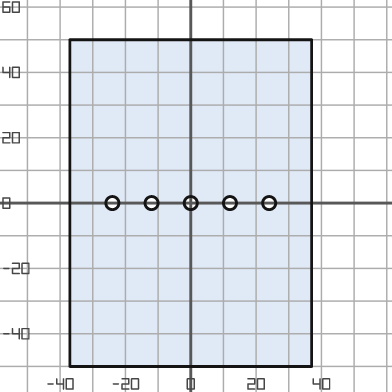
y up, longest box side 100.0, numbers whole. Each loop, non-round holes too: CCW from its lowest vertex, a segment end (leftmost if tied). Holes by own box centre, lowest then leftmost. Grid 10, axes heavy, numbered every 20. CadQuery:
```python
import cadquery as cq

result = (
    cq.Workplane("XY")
    .moveTo(-37.0, -50.0)
    .lineTo(37.0, -50.0)
    .lineTo(37.0, 50.0)
    .lineTo(-37.0, 50.0)
    .close()
    .moveTo(-24.0, 0.0)
    .circle(2.0)
    .moveTo(-12.0, 0.0)
    .circle(2.0)
    .moveTo(0.0, 0.0)
    .circle(2.0)
    .moveTo(12.0, 0.0)
    .circle(2.0)
    .moveTo(24.0, 0.0)
    .circle(2.0)
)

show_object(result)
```